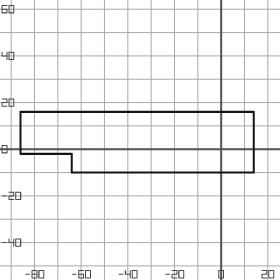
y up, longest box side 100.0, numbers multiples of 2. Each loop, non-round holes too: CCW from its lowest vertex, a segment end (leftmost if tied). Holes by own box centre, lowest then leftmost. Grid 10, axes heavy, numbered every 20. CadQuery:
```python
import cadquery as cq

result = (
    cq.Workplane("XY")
    .moveTo(-64.0, -10.0)
    .lineTo(14.0, -10.0)
    .lineTo(14.0, 16.0)
    .lineTo(-86.0, 16.0)
    .lineTo(-86.0, -2.0)
    .lineTo(-64.0, -2.0)
    .close()
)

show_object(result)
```